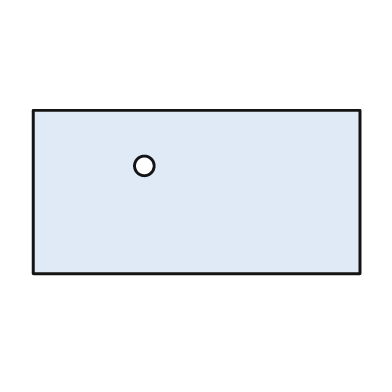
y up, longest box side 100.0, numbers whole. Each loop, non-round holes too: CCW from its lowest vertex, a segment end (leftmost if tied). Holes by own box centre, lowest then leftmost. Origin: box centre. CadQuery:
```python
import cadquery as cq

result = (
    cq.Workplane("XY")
    .moveTo(-50.0, -25.0)
    .lineTo(50.0, -25.0)
    .lineTo(50.0, 25.0)
    .lineTo(-50.0, 25.0)
    .close()
    .moveTo(-16.0, 8.0)
    .circle(3.0)
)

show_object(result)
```